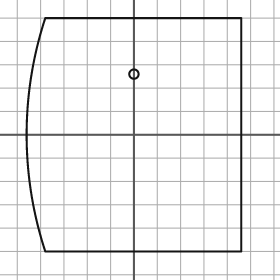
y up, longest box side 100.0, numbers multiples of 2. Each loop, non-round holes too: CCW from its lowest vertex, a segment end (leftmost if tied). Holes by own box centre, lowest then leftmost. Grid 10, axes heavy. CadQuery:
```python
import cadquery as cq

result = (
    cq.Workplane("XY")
    .moveTo(-38.0, -50.0)
    .lineTo(46.0, -50.0)
    .lineTo(46.0, 50.0)
    .lineTo(-38.0, 50.0)
    .threePointArc((-46.0, 0.0), (-38.0, -50.0))
    .close()
    .moveTo(0.0, 26.0)
    .circle(2.0)
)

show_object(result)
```